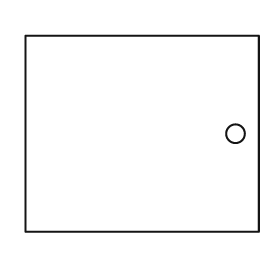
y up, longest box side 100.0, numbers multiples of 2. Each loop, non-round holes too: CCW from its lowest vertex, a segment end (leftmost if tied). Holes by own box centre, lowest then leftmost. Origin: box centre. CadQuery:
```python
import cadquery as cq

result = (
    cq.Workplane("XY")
    .moveTo(-50.0, -42.0)
    .lineTo(50.0, -42.0)
    .lineTo(50.0, 42.0)
    .lineTo(-50.0, 42.0)
    .close()
    .moveTo(40.0, 0.0)
    .circle(4.0)
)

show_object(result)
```